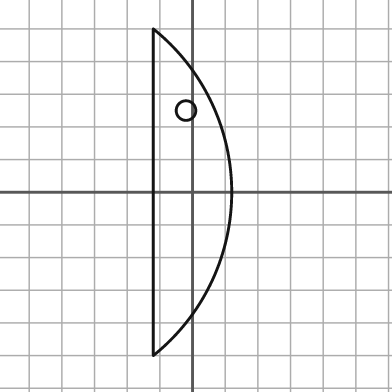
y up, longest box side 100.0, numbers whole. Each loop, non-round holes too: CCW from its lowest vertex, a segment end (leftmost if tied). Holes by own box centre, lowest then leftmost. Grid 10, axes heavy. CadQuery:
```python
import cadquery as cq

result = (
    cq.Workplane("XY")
    .moveTo(-12.0, -50.0)
    .threePointArc((12.0, 0.0), (-12.0, 50.0))
    .close()
    .moveTo(-2.0, 25.0)
    .circle(3.0)
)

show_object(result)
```